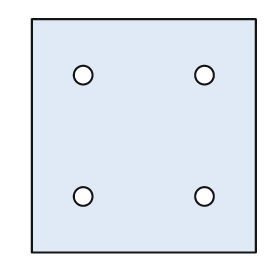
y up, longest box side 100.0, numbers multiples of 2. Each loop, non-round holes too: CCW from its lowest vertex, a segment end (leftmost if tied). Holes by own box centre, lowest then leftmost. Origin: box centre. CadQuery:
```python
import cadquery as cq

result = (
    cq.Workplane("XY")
    .moveTo(-48.0, -50.0)
    .lineTo(48.0, -50.0)
    .lineTo(48.0, 50.0)
    .lineTo(-48.0, 50.0)
    .close()
    .moveTo(-26.0, -26.0)
    .circle(4.0)
    .moveTo(26.0, -26.0)
    .circle(4.0)
    .moveTo(-26.0, 26.0)
    .circle(4.0)
    .moveTo(26.0, 26.0)
    .circle(4.0)
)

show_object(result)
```